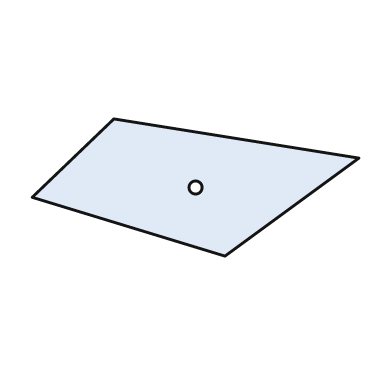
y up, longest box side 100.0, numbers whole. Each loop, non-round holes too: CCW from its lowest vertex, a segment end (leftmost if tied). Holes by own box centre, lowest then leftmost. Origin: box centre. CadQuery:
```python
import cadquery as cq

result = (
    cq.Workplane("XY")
    .moveTo(9.0, -21.0)
    .lineTo(50.0, 9.0)
    .lineTo(-25.0, 21.0)
    .lineTo(-50.0, -3.0)
    .close()
    .moveTo(0.0, 0.0)
    .circle(2.0)
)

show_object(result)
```